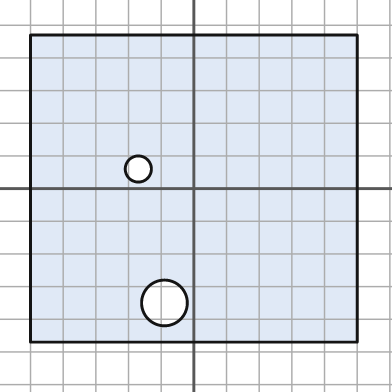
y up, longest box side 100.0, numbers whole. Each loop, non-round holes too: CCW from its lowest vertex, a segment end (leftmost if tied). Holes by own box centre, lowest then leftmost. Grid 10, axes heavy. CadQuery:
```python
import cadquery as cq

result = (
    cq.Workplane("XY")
    .moveTo(-50.0, -47.0)
    .lineTo(50.0, -47.0)
    .lineTo(50.0, 47.0)
    .lineTo(-50.0, 47.0)
    .close()
    .moveTo(-9.0, -35.0)
    .circle(7.0)
    .moveTo(-17.0, 6.0)
    .circle(4.0)
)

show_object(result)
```